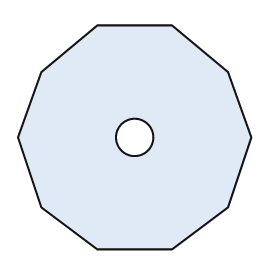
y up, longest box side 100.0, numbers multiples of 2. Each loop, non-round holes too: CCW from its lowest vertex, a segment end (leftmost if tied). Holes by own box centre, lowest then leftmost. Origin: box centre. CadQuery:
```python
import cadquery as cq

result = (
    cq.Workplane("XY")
    .moveTo(-16.0, -48.0)
    .lineTo(16.0, -48.0)
    .lineTo(40.0, -30.0)
    .lineTo(50.0, 0.0)
    .lineTo(40.0, 28.0)
    .lineTo(16.0, 48.0)
    .lineTo(-16.0, 48.0)
    .lineTo(-40.0, 28.0)
    .lineTo(-50.0, 0.0)
    .lineTo(-40.0, -30.0)
    .close()
    .moveTo(0.0, 0.0)
    .circle(8.0)
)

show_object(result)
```